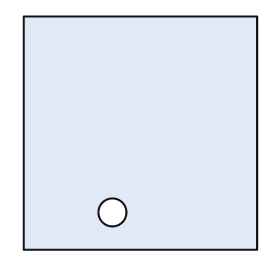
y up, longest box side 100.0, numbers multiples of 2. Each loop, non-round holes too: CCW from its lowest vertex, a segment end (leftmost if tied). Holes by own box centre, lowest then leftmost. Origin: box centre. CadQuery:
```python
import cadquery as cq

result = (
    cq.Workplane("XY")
    .moveTo(-50.0, -50.0)
    .lineTo(50.0, -50.0)
    .lineTo(50.0, 50.0)
    .lineTo(-50.0, 50.0)
    .close()
    .moveTo(-12.0, -34.0)
    .circle(6.0)
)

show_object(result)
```